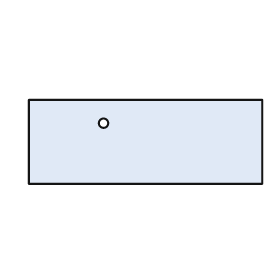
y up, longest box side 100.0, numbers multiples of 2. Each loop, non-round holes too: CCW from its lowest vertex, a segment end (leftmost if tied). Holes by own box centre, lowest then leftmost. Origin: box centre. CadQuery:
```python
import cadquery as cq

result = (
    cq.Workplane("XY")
    .moveTo(-50.0, -18.0)
    .lineTo(50.0, -18.0)
    .lineTo(50.0, 18.0)
    .lineTo(-50.0, 18.0)
    .close()
    .moveTo(-18.0, 8.0)
    .circle(2.0)
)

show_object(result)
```